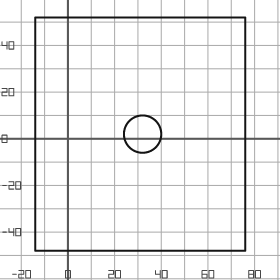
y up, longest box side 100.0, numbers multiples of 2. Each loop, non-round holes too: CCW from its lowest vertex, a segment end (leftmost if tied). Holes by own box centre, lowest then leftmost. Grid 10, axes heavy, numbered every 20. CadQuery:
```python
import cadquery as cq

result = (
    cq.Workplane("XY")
    .moveTo(-14.0, -48.0)
    .lineTo(76.0, -48.0)
    .lineTo(76.0, 52.0)
    .lineTo(-14.0, 52.0)
    .close()
    .moveTo(32.0, 2.0)
    .circle(8.0)
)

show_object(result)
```